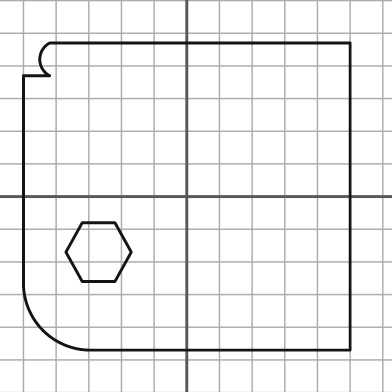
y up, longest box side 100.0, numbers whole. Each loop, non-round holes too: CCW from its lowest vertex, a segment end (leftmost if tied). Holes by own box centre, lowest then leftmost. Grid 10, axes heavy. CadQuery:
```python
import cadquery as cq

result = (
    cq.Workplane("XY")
    .moveTo(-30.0, -47.0)
    .lineTo(50.0, -47.0)
    .lineTo(50.0, 47.0)
    .lineTo(-42.0, 47.0)
    .threePointArc((-45.0, 42.0), (-42.0, 37.0))
    .lineTo(-50.0, 37.0)
    .lineTo(-50.0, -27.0)
    .threePointArc((-44.0, -41.0), (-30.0, -47.0))
    .close()
    .moveTo(-32.0, -26.0)
    .lineTo(-22.0, -26.0)
    .lineTo(-17.0, -17.0)
    .lineTo(-22.0, -8.0)
    .lineTo(-32.0, -8.0)
    .lineTo(-37.0, -17.0)
    .close()
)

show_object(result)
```